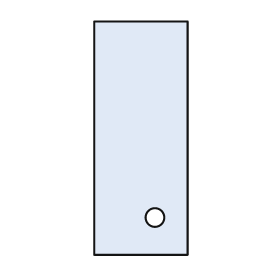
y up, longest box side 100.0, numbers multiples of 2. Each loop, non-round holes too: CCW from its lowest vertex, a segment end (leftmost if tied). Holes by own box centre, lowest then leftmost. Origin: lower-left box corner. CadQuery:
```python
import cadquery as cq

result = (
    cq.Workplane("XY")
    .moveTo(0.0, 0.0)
    .lineTo(40.0, 0.0)
    .lineTo(40.0, 100.0)
    .lineTo(0.0, 100.0)
    .close()
    .moveTo(26.0, 16.0)
    .circle(4.0)
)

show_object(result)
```